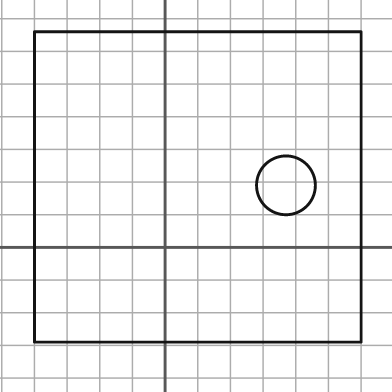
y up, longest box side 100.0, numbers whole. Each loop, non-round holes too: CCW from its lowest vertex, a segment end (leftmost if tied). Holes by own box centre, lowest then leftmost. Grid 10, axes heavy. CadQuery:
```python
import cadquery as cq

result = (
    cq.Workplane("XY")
    .moveTo(-40.0, -29.0)
    .lineTo(60.0, -29.0)
    .lineTo(60.0, 66.0)
    .lineTo(-40.0, 66.0)
    .close()
    .moveTo(37.0, 19.0)
    .circle(9.0)
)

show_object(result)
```